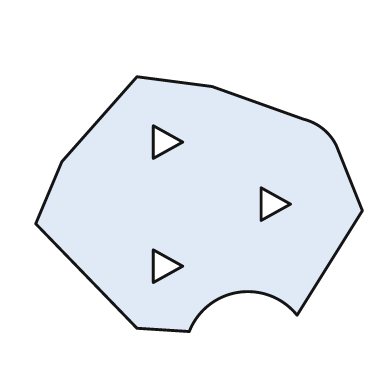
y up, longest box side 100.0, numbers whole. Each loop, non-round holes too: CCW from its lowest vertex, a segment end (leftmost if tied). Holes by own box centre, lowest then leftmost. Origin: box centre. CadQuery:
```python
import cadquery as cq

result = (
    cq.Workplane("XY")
    .moveTo(-3.0, -39.0)
    .threePointArc((12.0, -27.0), (30.0, -34.0))
    .lineTo(50.0, -2.0)
    .lineTo(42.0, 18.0)
    .threePointArc((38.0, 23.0), (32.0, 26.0))
    .lineTo(4.0, 36.0)
    .lineTo(-19.0, 39.0)
    .lineTo(-42.0, 13.0)
    .lineTo(-50.0, -6.0)
    .lineTo(-19.0, -38.0)
    .close()
    .moveTo(-14.0, -24.0)
    .lineTo(-5.0, -19.0)
    .lineTo(-14.0, -14.0)
    .close()
    .moveTo(19.0, -5.0)
    .lineTo(28.0, 0.0)
    .lineTo(19.0, 5.0)
    .close()
    .moveTo(-14.0, 14.0)
    .lineTo(-5.0, 19.0)
    .lineTo(-14.0, 24.0)
    .close()
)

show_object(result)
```